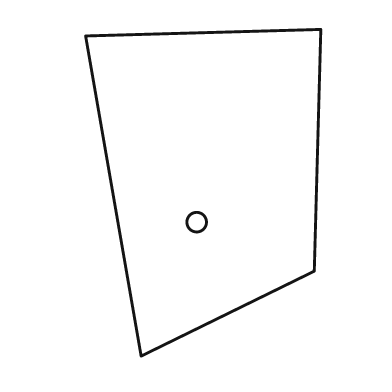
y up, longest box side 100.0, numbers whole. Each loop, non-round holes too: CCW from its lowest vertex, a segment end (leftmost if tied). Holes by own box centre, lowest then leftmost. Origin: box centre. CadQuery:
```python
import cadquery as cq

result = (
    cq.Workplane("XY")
    .moveTo(-19.0, -50.0)
    .lineTo(34.0, -24.0)
    .lineTo(36.0, 50.0)
    .lineTo(-36.0, 48.0)
    .close()
    .moveTo(-2.0, -9.0)
    .circle(3.0)
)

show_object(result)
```